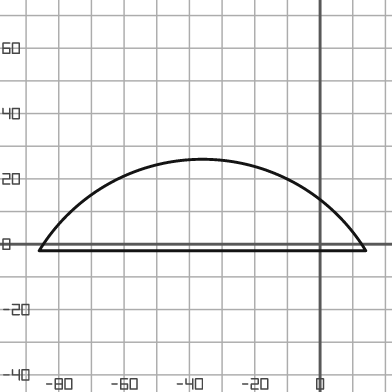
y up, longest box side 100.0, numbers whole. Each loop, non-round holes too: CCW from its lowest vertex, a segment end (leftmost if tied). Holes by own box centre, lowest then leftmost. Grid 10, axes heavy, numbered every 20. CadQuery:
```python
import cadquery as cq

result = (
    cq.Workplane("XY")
    .moveTo(-86.0, -2.0)
    .lineTo(14.0, -2.0)
    .threePointArc((-36.0, 26.0), (-86.0, -2.0))
    .close()
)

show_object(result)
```